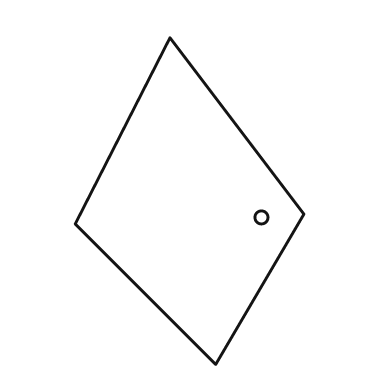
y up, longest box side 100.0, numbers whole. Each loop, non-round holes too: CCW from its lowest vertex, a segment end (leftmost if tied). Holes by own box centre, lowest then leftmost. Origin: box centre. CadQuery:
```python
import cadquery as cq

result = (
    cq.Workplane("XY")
    .moveTo(8.0, -50.0)
    .lineTo(35.0, -4.0)
    .lineTo(-6.0, 50.0)
    .lineTo(-35.0, -7.0)
    .close()
    .moveTo(22.0, -5.0)
    .circle(2.0)
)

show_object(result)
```